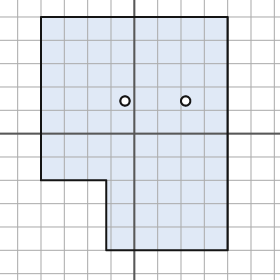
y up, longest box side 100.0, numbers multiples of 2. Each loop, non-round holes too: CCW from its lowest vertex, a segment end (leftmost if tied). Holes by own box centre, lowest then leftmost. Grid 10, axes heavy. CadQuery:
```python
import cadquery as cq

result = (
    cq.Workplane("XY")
    .moveTo(-12.0, -50.0)
    .lineTo(40.0, -50.0)
    .lineTo(40.0, 50.0)
    .lineTo(-40.0, 50.0)
    .lineTo(-40.0, -20.0)
    .lineTo(-12.0, -20.0)
    .close()
    .moveTo(-4.0, 14.0)
    .circle(2.0)
    .moveTo(22.0, 14.0)
    .circle(2.0)
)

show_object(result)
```